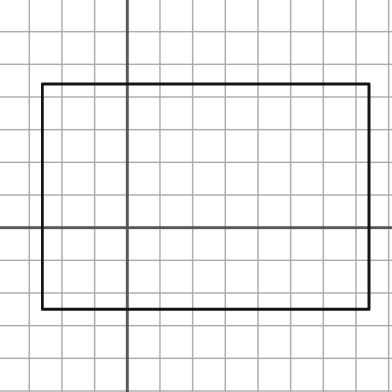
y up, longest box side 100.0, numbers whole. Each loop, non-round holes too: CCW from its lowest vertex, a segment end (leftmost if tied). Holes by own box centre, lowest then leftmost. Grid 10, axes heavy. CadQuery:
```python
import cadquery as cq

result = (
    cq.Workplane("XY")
    .moveTo(-26.0, -25.0)
    .lineTo(74.0, -25.0)
    .lineTo(74.0, 44.0)
    .lineTo(-26.0, 44.0)
    .close()
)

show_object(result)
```